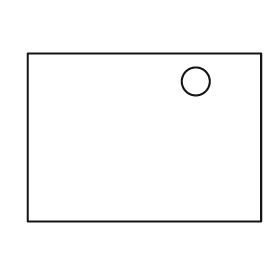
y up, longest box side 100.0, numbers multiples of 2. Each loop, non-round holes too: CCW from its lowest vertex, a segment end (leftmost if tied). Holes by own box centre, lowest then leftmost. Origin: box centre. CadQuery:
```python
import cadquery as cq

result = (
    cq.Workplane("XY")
    .moveTo(-50.0, -36.0)
    .lineTo(50.0, -36.0)
    .lineTo(50.0, 36.0)
    .lineTo(-50.0, 36.0)
    .close()
    .moveTo(22.0, 24.0)
    .circle(6.0)
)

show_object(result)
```